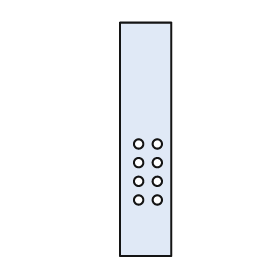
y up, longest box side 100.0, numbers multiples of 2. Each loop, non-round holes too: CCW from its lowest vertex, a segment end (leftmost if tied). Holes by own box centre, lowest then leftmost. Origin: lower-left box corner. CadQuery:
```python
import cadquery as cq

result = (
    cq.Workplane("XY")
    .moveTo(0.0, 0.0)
    .lineTo(22.0, 0.0)
    .lineTo(22.0, 100.0)
    .lineTo(0.0, 100.0)
    .close()
    .moveTo(8.0, 24.0)
    .circle(2.0)
    .moveTo(16.0, 24.0)
    .circle(2.0)
    .moveTo(8.0, 32.0)
    .circle(2.0)
    .moveTo(16.0, 32.0)
    .circle(2.0)
    .moveTo(8.0, 40.0)
    .circle(2.0)
    .moveTo(16.0, 40.0)
    .circle(2.0)
    .moveTo(8.0, 48.0)
    .circle(2.0)
    .moveTo(16.0, 48.0)
    .circle(2.0)
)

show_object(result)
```